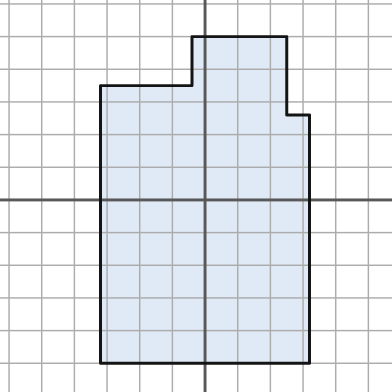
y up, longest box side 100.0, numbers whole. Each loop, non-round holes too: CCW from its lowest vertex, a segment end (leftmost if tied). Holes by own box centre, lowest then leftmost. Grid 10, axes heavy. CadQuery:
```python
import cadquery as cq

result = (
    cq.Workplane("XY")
    .moveTo(-32.0, -50.0)
    .lineTo(32.0, -50.0)
    .lineTo(32.0, 26.0)
    .lineTo(25.0, 26.0)
    .lineTo(25.0, 50.0)
    .lineTo(-4.0, 50.0)
    .lineTo(-4.0, 35.0)
    .lineTo(-32.0, 35.0)
    .close()
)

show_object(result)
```